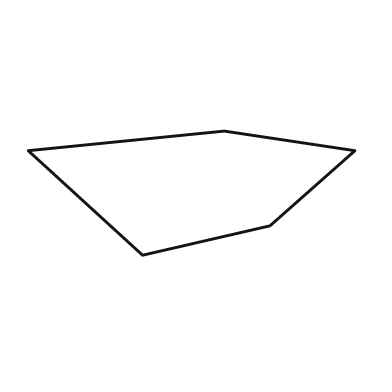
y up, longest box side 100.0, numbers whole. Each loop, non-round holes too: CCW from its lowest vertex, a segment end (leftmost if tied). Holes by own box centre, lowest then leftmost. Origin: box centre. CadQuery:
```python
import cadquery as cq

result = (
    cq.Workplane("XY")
    .moveTo(-15.0, -19.0)
    .lineTo(24.0, -10.0)
    .lineTo(50.0, 13.0)
    .lineTo(10.0, 19.0)
    .lineTo(-50.0, 13.0)
    .close()
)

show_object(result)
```